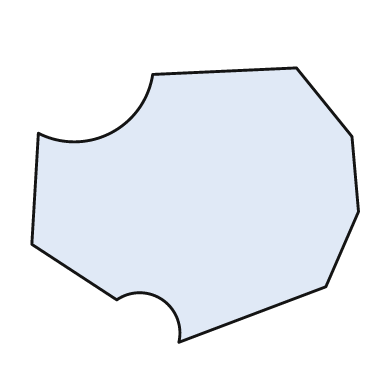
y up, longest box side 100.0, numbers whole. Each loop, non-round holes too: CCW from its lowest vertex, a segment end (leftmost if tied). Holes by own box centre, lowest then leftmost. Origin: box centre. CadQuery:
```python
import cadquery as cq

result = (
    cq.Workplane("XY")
    .moveTo(-5.0, -42.0)
    .lineTo(40.0, -25.0)
    .lineTo(50.0, -2.0)
    .lineTo(48.0, 21.0)
    .lineTo(31.0, 42.0)
    .lineTo(-13.0, 40.0)
    .threePointArc((-26.0, 22.0), (-48.0, 22.0))
    .lineTo(-50.0, -12.0)
    .lineTo(-24.0, -29.0)
    .threePointArc((-10.0, -29.0), (-5.0, -42.0))
    .close()
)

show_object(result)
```